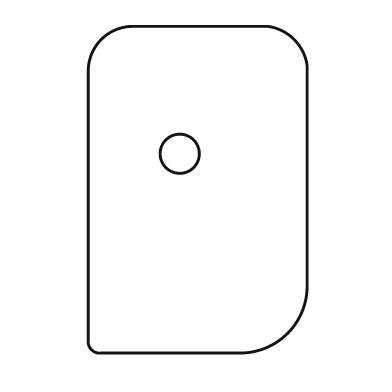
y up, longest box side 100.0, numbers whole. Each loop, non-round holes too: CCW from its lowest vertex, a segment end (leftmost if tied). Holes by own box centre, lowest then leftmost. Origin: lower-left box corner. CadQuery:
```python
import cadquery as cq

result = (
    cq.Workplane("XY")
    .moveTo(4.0, 0.0)
    .lineTo(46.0, 0.0)
    .threePointArc((61.0, 6.0), (67.0, 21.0))
    .lineTo(67.0, 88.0)
    .threePointArc((63.0, 96.0), (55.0, 100.0))
    .lineTo(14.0, 100.0)
    .threePointArc((4.0, 96.0), (0.0, 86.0))
    .lineTo(0.0, 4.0)
    .threePointArc((1.0, 1.0), (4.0, 0.0))
    .close()
    .moveTo(28.0, 61.0)
    .circle(6.0)
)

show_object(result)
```